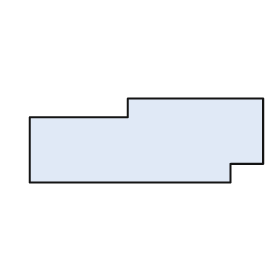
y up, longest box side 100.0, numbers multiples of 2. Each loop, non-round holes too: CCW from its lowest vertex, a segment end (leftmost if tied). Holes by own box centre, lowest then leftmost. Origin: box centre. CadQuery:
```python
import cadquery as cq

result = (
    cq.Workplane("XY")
    .moveTo(-50.0, -18.0)
    .lineTo(36.0, -18.0)
    .lineTo(36.0, -10.0)
    .lineTo(50.0, -10.0)
    .lineTo(50.0, 18.0)
    .lineTo(-8.0, 18.0)
    .lineTo(-8.0, 10.0)
    .lineTo(-50.0, 10.0)
    .close()
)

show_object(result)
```